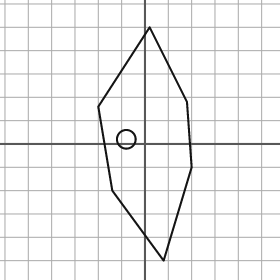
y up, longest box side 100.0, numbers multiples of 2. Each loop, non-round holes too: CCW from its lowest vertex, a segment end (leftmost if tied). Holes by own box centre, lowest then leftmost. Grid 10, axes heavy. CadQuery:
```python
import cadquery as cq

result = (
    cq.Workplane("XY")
    .moveTo(8.0, -50.0)
    .lineTo(20.0, -10.0)
    .lineTo(18.0, 18.0)
    .lineTo(2.0, 50.0)
    .lineTo(-20.0, 16.0)
    .lineTo(-14.0, -20.0)
    .close()
    .moveTo(-8.0, 2.0)
    .circle(4.0)
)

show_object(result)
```